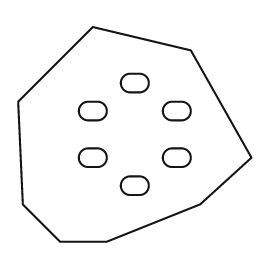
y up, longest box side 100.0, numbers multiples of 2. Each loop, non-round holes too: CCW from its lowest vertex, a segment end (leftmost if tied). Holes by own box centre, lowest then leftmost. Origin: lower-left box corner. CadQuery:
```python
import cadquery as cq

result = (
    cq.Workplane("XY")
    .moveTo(18.0, 0.0)
    .lineTo(38.0, 0.0)
    .lineTo(78.0, 16.0)
    .lineTo(100.0, 36.0)
    .lineTo(74.0, 82.0)
    .lineTo(32.0, 92.0)
    .lineTo(0.0, 60.0)
    .lineTo(2.0, 16.0)
    .close()
    .moveTo(48.0, 20.0)
    .lineTo(52.0, 20.0)
    .threePointArc((56.0, 24.0), (52.0, 28.0))
    .lineTo(48.0, 28.0)
    .threePointArc((44.0, 24.0), (48.0, 20.0))
    .close()
    .moveTo(30.0, 32.0)
    .lineTo(34.0, 32.0)
    .threePointArc((38.0, 36.0), (34.0, 40.0))
    .lineTo(30.0, 40.0)
    .threePointArc((26.0, 36.0), (30.0, 32.0))
    .close()
    .moveTo(66.0, 32.0)
    .lineTo(70.0, 32.0)
    .threePointArc((74.0, 36.0), (70.0, 40.0))
    .lineTo(66.0, 40.0)
    .threePointArc((62.0, 36.0), (66.0, 32.0))
    .close()
    .moveTo(30.0, 52.0)
    .lineTo(34.0, 52.0)
    .threePointArc((38.0, 56.0), (34.0, 60.0))
    .lineTo(30.0, 60.0)
    .threePointArc((26.0, 56.0), (30.0, 52.0))
    .close()
    .moveTo(66.0, 52.0)
    .lineTo(70.0, 52.0)
    .threePointArc((74.0, 56.0), (70.0, 60.0))
    .lineTo(66.0, 60.0)
    .threePointArc((62.0, 56.0), (66.0, 52.0))
    .close()
    .moveTo(48.0, 64.0)
    .lineTo(52.0, 64.0)
    .threePointArc((56.0, 68.0), (52.0, 72.0))
    .lineTo(48.0, 72.0)
    .threePointArc((44.0, 68.0), (48.0, 64.0))
    .close()
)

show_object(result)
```